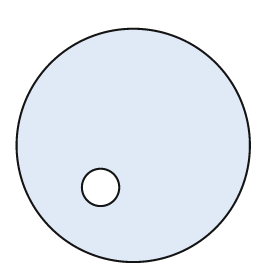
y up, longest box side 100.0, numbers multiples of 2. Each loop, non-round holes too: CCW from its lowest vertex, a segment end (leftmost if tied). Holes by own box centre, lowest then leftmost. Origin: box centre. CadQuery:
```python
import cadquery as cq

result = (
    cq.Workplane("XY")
    .moveTo(0.0, 0.0)
    .circle(50.0)
    .moveTo(-14.0, -18.0)
    .circle(8.0)
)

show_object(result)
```